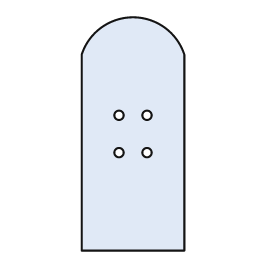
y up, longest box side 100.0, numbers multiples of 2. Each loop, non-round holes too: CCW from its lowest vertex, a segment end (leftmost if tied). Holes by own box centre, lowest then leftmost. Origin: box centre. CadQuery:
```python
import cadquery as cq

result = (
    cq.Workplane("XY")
    .moveTo(-22.0, -50.0)
    .lineTo(22.0, -50.0)
    .lineTo(22.0, 34.0)
    .threePointArc((0.0, 50.0), (-22.0, 34.0))
    .close()
    .moveTo(-6.0, -8.0)
    .circle(2.0)
    .moveTo(6.0, -8.0)
    .circle(2.0)
    .moveTo(-6.0, 8.0)
    .circle(2.0)
    .moveTo(6.0, 8.0)
    .circle(2.0)
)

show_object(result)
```